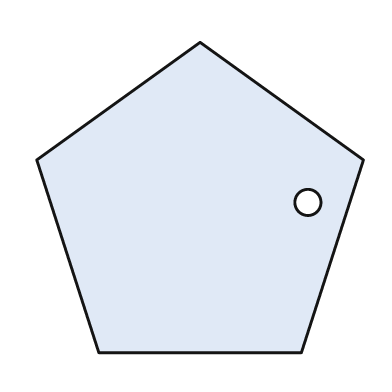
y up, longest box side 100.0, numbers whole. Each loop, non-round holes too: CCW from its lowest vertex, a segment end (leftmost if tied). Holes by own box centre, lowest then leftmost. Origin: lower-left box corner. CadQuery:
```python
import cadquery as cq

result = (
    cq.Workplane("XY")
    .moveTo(19.0, 0.0)
    .lineTo(81.0, 0.0)
    .lineTo(100.0, 59.0)
    .lineTo(50.0, 95.0)
    .lineTo(0.0, 59.0)
    .close()
    .moveTo(83.0, 46.0)
    .circle(4.0)
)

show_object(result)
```